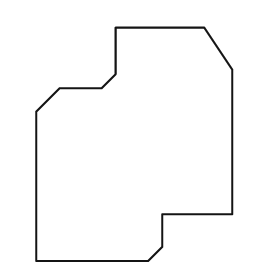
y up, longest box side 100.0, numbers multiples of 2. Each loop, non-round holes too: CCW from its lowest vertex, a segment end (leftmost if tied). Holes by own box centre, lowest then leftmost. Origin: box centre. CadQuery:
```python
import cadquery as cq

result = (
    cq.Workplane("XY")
    .moveTo(-42.0, -50.0)
    .lineTo(6.0, -50.0)
    .lineTo(12.0, -44.0)
    .lineTo(12.0, -30.0)
    .lineTo(42.0, -30.0)
    .lineTo(42.0, 32.0)
    .lineTo(30.0, 50.0)
    .lineTo(-8.0, 50.0)
    .lineTo(-8.0, 30.0)
    .lineTo(-14.0, 24.0)
    .lineTo(-32.0, 24.0)
    .lineTo(-42.0, 14.0)
    .close()
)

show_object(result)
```